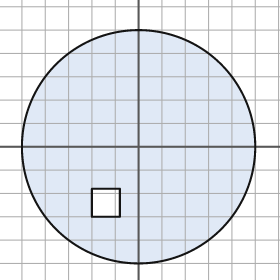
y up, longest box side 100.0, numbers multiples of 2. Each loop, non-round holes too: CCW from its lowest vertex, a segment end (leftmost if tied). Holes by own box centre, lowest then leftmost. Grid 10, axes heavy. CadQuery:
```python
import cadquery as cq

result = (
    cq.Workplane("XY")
    .moveTo(0.0, 0.0)
    .circle(50.0)
    .moveTo(-20.0, -30.0)
    .lineTo(-8.0, -30.0)
    .lineTo(-8.0, -18.0)
    .lineTo(-20.0, -18.0)
    .close()
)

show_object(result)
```